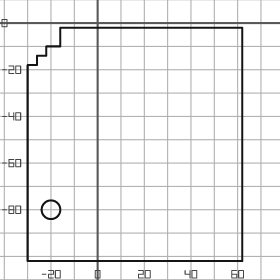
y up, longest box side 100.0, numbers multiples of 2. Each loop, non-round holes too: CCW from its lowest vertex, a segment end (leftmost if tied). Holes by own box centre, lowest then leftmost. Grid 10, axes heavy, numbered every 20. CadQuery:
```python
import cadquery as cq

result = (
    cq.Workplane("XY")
    .moveTo(-30.0, -102.0)
    .lineTo(62.0, -102.0)
    .lineTo(62.0, -2.0)
    .lineTo(-16.0, -2.0)
    .lineTo(-16.0, -10.0)
    .lineTo(-22.0, -10.0)
    .lineTo(-22.0, -14.0)
    .lineTo(-26.0, -14.0)
    .lineTo(-26.0, -18.0)
    .lineTo(-30.0, -18.0)
    .close()
    .moveTo(-20.0, -80.0)
    .circle(4.0)
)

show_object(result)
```